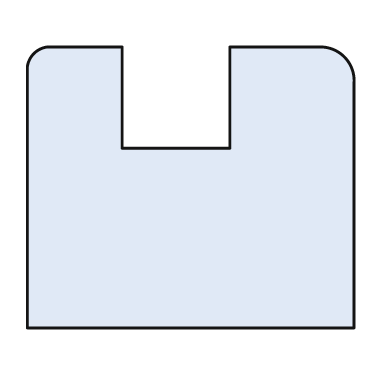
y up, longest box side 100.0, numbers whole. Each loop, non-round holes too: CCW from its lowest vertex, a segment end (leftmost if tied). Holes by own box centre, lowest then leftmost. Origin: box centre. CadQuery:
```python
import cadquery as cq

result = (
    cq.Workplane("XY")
    .moveTo(-50.0, -43.0)
    .lineTo(50.0, -43.0)
    .lineTo(50.0, 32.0)
    .threePointArc((47.0, 40.0), (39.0, 43.0))
    .lineTo(12.0, 43.0)
    .lineTo(12.0, 12.0)
    .lineTo(-21.0, 12.0)
    .lineTo(-21.0, 43.0)
    .lineTo(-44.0, 43.0)
    .threePointArc((-48.0, 41.0), (-50.0, 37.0))
    .close()
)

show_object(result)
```